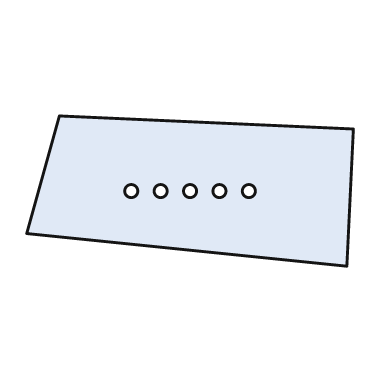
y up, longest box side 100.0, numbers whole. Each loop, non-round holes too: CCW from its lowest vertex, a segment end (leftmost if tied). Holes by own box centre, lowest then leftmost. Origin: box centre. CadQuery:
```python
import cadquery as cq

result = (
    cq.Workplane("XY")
    .moveTo(48.0, -23.0)
    .lineTo(50.0, 19.0)
    .lineTo(-40.0, 23.0)
    .lineTo(-50.0, -13.0)
    .close()
    .moveTo(-18.0, 0.0)
    .circle(2.0)
    .moveTo(-9.0, 0.0)
    .circle(2.0)
    .moveTo(0.0, 0.0)
    .circle(2.0)
    .moveTo(9.0, 0.0)
    .circle(2.0)
    .moveTo(18.0, 0.0)
    .circle(2.0)
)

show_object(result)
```